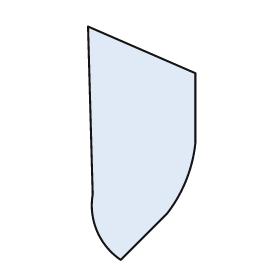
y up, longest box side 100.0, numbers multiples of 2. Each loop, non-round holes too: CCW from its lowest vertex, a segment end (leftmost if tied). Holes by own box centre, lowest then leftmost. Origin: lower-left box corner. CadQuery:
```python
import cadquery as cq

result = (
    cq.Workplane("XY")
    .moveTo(14.0, 0.0)
    .lineTo(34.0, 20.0)
    .threePointArc((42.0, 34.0), (46.0, 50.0))
    .lineTo(46.0, 80.0)
    .lineTo(0.0, 100.0)
    .lineTo(2.0, 28.0)
    .threePointArc((4.0, 12.0), (14.0, 0.0))
    .close()
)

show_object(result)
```